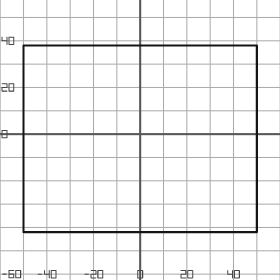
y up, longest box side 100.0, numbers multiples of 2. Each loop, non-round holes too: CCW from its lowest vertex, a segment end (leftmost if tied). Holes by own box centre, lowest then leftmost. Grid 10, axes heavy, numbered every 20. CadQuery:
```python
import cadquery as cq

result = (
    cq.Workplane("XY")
    .moveTo(-50.0, -42.0)
    .lineTo(50.0, -42.0)
    .lineTo(50.0, 38.0)
    .lineTo(-50.0, 38.0)
    .close()
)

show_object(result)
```